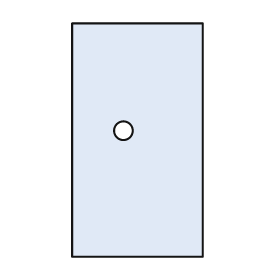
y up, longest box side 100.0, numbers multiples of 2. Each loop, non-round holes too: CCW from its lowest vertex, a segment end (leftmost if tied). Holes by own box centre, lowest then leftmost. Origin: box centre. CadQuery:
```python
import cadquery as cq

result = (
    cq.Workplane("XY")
    .moveTo(-28.0, -50.0)
    .lineTo(28.0, -50.0)
    .lineTo(28.0, 50.0)
    .lineTo(-28.0, 50.0)
    .close()
    .moveTo(-6.0, 4.0)
    .circle(4.0)
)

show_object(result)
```